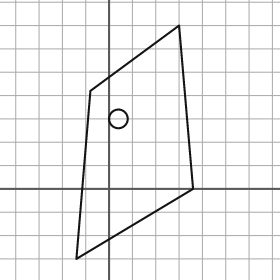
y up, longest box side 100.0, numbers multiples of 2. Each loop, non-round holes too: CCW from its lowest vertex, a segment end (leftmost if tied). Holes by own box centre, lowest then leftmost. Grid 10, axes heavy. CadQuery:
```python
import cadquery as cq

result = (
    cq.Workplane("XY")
    .moveTo(-14.0, -30.0)
    .lineTo(36.0, 0.0)
    .lineTo(30.0, 70.0)
    .lineTo(-8.0, 42.0)
    .close()
    .moveTo(4.0, 30.0)
    .circle(4.0)
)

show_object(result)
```